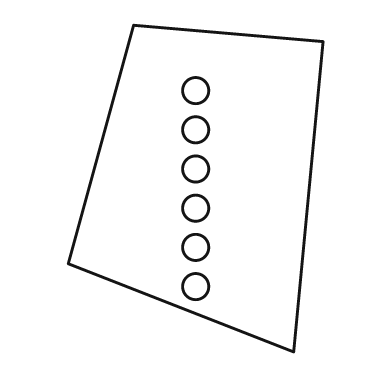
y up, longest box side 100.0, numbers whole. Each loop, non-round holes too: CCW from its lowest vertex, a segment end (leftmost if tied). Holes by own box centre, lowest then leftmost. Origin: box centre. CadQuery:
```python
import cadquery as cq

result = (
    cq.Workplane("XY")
    .moveTo(30.0, -50.0)
    .lineTo(39.0, 45.0)
    .lineTo(-19.0, 50.0)
    .lineTo(-39.0, -23.0)
    .close()
    .moveTo(0.0, -30.0)
    .circle(4.0)
    .moveTo(0.0, -18.0)
    .circle(4.0)
    .moveTo(0.0, -6.0)
    .circle(4.0)
    .moveTo(0.0, 6.0)
    .circle(4.0)
    .moveTo(0.0, 18.0)
    .circle(4.0)
    .moveTo(0.0, 30.0)
    .circle(4.0)
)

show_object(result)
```